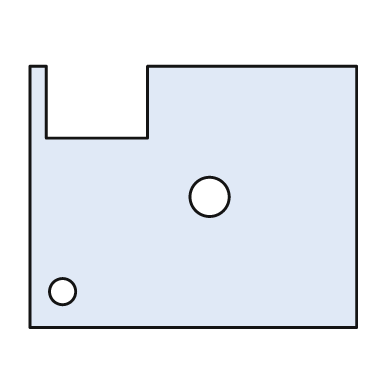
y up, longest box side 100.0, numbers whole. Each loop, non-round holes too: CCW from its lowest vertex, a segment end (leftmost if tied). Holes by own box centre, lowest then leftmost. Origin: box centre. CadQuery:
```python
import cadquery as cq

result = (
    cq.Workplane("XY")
    .moveTo(-50.0, -40.0)
    .lineTo(50.0, -40.0)
    .lineTo(50.0, 40.0)
    .lineTo(-14.0, 40.0)
    .lineTo(-14.0, 18.0)
    .lineTo(-45.0, 18.0)
    .lineTo(-45.0, 40.0)
    .lineTo(-50.0, 40.0)
    .close()
    .moveTo(-40.0, -29.0)
    .circle(4.0)
    .moveTo(5.0, 0.0)
    .circle(6.0)
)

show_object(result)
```